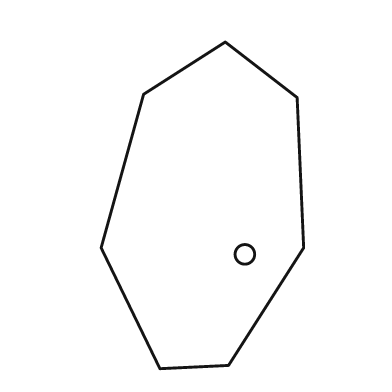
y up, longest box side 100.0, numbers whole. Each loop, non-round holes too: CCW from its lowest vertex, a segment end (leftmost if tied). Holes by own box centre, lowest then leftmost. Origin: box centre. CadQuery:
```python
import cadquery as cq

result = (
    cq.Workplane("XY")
    .moveTo(-13.0, -50.0)
    .lineTo(8.0, -49.0)
    .lineTo(31.0, -13.0)
    .lineTo(29.0, 33.0)
    .lineTo(7.0, 50.0)
    .lineTo(-18.0, 34.0)
    .lineTo(-31.0, -13.0)
    .close()
    .moveTo(13.0, -15.0)
    .circle(3.0)
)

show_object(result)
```